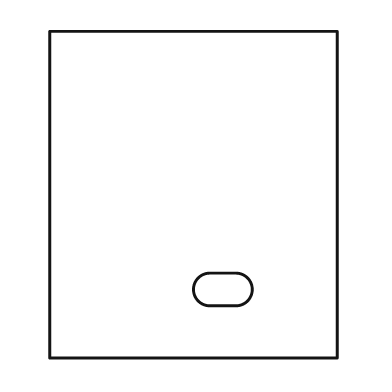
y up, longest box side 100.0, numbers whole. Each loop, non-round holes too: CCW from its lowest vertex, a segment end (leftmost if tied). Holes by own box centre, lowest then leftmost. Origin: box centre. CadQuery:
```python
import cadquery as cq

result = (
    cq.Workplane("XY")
    .moveTo(-44.0, -50.0)
    .lineTo(44.0, -50.0)
    .lineTo(44.0, 50.0)
    .lineTo(-44.0, 50.0)
    .close()
    .moveTo(5.0, -34.0)
    .lineTo(13.0, -34.0)
    .threePointArc((18.0, -29.0), (13.0, -24.0))
    .lineTo(5.0, -24.0)
    .threePointArc((0.0, -29.0), (5.0, -34.0))
    .close()
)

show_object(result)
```